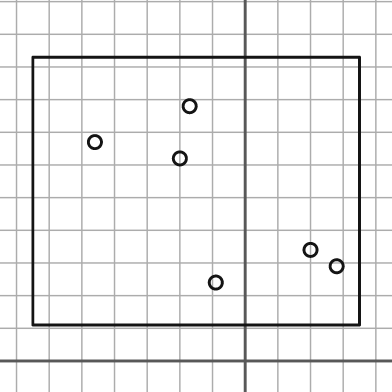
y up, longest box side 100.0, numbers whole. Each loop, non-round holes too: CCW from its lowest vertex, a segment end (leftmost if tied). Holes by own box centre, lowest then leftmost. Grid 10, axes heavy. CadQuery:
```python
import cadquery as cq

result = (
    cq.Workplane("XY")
    .moveTo(-65.0, 11.0)
    .lineTo(35.0, 11.0)
    .lineTo(35.0, 93.0)
    .lineTo(-65.0, 93.0)
    .close()
    .moveTo(-9.0, 24.0)
    .circle(2.0)
    .moveTo(28.0, 29.0)
    .circle(2.0)
    .moveTo(20.0, 34.0)
    .circle(2.0)
    .moveTo(-20.0, 62.0)
    .circle(2.0)
    .moveTo(-46.0, 67.0)
    .circle(2.0)
    .moveTo(-17.0, 78.0)
    .circle(2.0)
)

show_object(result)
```